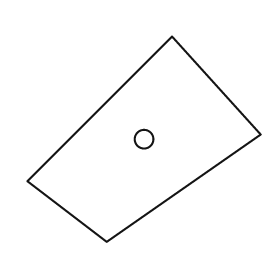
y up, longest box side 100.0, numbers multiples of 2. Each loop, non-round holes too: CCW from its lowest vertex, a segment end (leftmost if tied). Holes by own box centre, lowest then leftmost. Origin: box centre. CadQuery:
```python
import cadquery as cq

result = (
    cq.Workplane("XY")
    .moveTo(-16.0, -44.0)
    .lineTo(50.0, 2.0)
    .lineTo(12.0, 44.0)
    .lineTo(-50.0, -18.0)
    .close()
    .moveTo(0.0, 0.0)
    .circle(4.0)
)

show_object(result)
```